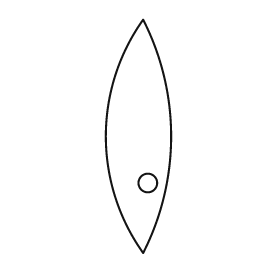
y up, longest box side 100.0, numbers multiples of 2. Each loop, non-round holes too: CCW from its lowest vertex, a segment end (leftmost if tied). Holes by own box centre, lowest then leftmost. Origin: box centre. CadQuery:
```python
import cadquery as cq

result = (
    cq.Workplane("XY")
    .moveTo(2.0, -50.0)
    .threePointArc((14.0, 0.0), (2.0, 50.0))
    .threePointArc((-14.0, 0.0), (2.0, -50.0))
    .close()
    .moveTo(4.0, -20.0)
    .circle(4.0)
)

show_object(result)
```